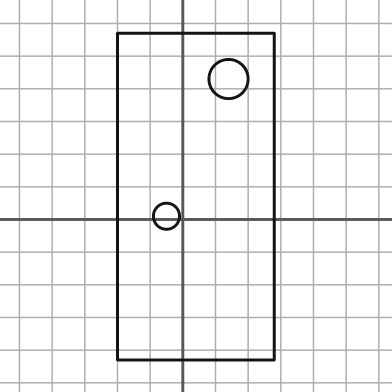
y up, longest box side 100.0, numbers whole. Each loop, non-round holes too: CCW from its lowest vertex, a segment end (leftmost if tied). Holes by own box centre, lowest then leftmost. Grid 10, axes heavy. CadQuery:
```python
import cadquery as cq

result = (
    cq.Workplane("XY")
    .moveTo(-20.0, -43.0)
    .lineTo(28.0, -43.0)
    .lineTo(28.0, 57.0)
    .lineTo(-20.0, 57.0)
    .close()
    .moveTo(-5.0, 1.0)
    .circle(4.0)
    .moveTo(14.0, 43.0)
    .circle(6.0)
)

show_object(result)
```